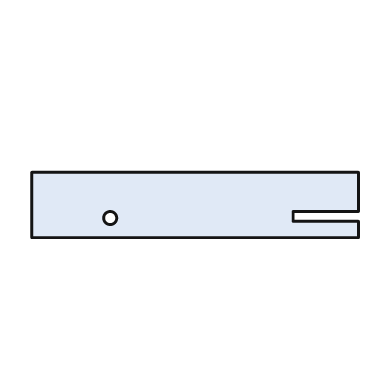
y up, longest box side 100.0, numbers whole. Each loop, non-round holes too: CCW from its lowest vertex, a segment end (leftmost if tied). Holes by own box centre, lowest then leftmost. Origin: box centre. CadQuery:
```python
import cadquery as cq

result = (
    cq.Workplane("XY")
    .moveTo(-50.0, -10.0)
    .lineTo(50.0, -10.0)
    .lineTo(50.0, -5.0)
    .lineTo(30.0, -5.0)
    .lineTo(30.0, -2.0)
    .lineTo(50.0, -2.0)
    .lineTo(50.0, 10.0)
    .lineTo(-50.0, 10.0)
    .close()
    .moveTo(-26.0, -4.0)
    .circle(2.0)
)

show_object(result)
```